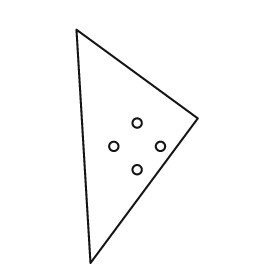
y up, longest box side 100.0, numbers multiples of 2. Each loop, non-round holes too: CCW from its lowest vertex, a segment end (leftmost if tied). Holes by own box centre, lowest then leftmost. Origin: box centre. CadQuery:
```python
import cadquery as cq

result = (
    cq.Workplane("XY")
    .moveTo(-20.0, -50.0)
    .lineTo(26.0, 12.0)
    .lineTo(-26.0, 50.0)
    .close()
    .moveTo(0.0, -10.0)
    .circle(2.0)
    .moveTo(-10.0, 0.0)
    .circle(2.0)
    .moveTo(10.0, 0.0)
    .circle(2.0)
    .moveTo(0.0, 10.0)
    .circle(2.0)
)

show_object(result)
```